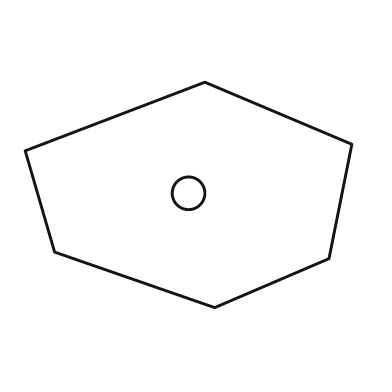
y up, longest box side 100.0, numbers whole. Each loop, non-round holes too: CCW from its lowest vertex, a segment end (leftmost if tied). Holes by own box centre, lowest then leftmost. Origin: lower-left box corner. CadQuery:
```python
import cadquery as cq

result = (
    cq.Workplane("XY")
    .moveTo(58.0, 0.0)
    .lineTo(93.0, 15.0)
    .lineTo(100.0, 50.0)
    .lineTo(55.0, 69.0)
    .lineTo(0.0, 48.0)
    .lineTo(9.0, 17.0)
    .close()
    .moveTo(50.0, 35.0)
    .circle(5.0)
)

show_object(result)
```